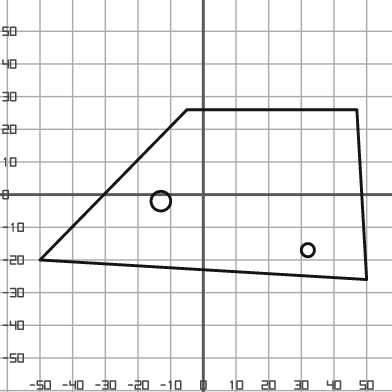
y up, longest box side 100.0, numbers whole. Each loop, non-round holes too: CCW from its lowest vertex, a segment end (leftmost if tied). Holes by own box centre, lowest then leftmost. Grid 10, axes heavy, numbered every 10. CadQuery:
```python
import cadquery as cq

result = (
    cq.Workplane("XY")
    .moveTo(50.0, -26.0)
    .lineTo(47.0, 26.0)
    .lineTo(-5.0, 26.0)
    .lineTo(-50.0, -20.0)
    .close()
    .moveTo(32.0, -17.0)
    .circle(2.0)
    .moveTo(-13.0, -2.0)
    .circle(3.0)
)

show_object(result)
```